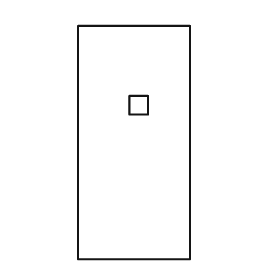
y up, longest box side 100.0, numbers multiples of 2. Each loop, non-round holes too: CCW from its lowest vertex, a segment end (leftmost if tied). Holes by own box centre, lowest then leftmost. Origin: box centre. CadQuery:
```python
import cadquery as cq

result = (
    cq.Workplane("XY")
    .moveTo(-24.0, -50.0)
    .lineTo(24.0, -50.0)
    .lineTo(24.0, 50.0)
    .lineTo(-24.0, 50.0)
    .close()
    .moveTo(-2.0, 12.0)
    .lineTo(6.0, 12.0)
    .lineTo(6.0, 20.0)
    .lineTo(-2.0, 20.0)
    .close()
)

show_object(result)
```